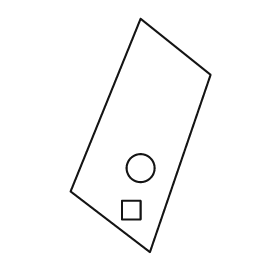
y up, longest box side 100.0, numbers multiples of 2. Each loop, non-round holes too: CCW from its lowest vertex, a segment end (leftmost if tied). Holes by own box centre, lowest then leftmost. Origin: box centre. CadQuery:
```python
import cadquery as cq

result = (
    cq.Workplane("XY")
    .moveTo(4.0, -50.0)
    .lineTo(30.0, 26.0)
    .lineTo(0.0, 50.0)
    .lineTo(-30.0, -24.0)
    .close()
    .moveTo(-8.0, -36.0)
    .lineTo(0.0, -36.0)
    .lineTo(0.0, -28.0)
    .lineTo(-8.0, -28.0)
    .close()
    .moveTo(0.0, -14.0)
    .circle(6.0)
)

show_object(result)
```